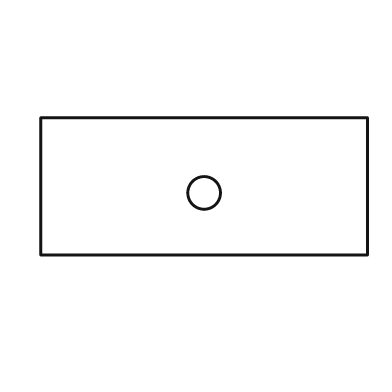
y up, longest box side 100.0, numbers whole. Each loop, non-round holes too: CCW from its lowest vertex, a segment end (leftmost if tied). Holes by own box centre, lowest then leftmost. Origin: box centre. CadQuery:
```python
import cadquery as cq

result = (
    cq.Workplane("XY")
    .moveTo(-50.0, -21.0)
    .lineTo(50.0, -21.0)
    .lineTo(50.0, 21.0)
    .lineTo(-50.0, 21.0)
    .close()
    .moveTo(0.0, -2.0)
    .circle(5.0)
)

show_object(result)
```